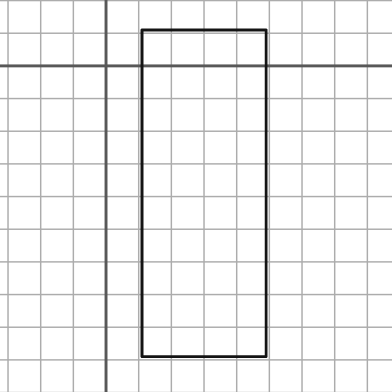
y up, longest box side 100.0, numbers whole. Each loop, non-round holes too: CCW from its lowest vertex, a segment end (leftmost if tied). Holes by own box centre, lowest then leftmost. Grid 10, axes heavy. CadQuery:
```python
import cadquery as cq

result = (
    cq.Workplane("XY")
    .moveTo(11.0, -89.0)
    .lineTo(49.0, -89.0)
    .lineTo(49.0, 11.0)
    .lineTo(11.0, 11.0)
    .close()
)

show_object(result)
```